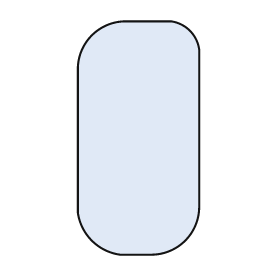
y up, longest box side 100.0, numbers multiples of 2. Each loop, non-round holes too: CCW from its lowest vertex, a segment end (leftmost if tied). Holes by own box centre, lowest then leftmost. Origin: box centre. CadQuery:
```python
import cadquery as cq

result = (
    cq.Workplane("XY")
    .moveTo(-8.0, -50.0)
    .lineTo(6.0, -50.0)
    .threePointArc((20.0, -44.0), (26.0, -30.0))
    .lineTo(26.0, 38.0)
    .threePointArc((22.0, 46.0), (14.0, 50.0))
    .lineTo(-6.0, 50.0)
    .threePointArc((-20.0, 44.0), (-26.0, 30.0))
    .lineTo(-26.0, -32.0)
    .threePointArc((-20.0, -44.0), (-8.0, -50.0))
    .close()
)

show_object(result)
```